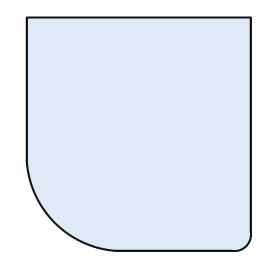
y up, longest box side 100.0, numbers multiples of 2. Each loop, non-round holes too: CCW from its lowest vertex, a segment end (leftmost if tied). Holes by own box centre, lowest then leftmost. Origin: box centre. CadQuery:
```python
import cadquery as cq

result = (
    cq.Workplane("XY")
    .moveTo(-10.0, -50.0)
    .lineTo(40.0, -50.0)
    .threePointArc((46.0, -48.0), (48.0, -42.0))
    .lineTo(48.0, 50.0)
    .lineTo(-48.0, 50.0)
    .lineTo(-48.0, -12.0)
    .threePointArc((-36.0, -38.0), (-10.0, -50.0))
    .close()
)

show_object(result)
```